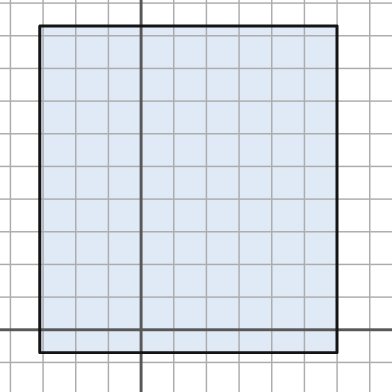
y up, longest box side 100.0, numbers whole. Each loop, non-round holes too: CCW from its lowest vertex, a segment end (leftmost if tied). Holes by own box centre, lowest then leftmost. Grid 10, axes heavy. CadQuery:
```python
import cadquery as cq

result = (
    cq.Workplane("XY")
    .moveTo(-31.0, -7.0)
    .lineTo(60.0, -7.0)
    .lineTo(60.0, 93.0)
    .lineTo(-31.0, 93.0)
    .close()
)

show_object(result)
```